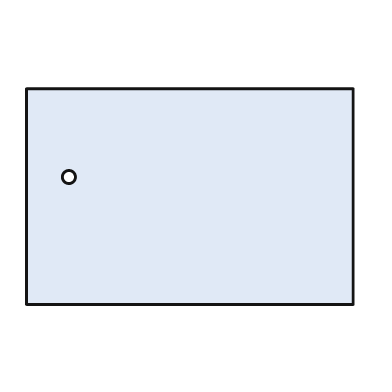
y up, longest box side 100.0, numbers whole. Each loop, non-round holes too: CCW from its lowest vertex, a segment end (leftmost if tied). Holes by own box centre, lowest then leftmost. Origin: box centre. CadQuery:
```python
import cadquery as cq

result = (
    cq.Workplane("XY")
    .moveTo(-50.0, -33.0)
    .lineTo(50.0, -33.0)
    .lineTo(50.0, 33.0)
    .lineTo(-50.0, 33.0)
    .close()
    .moveTo(-37.0, 6.0)
    .circle(2.0)
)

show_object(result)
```